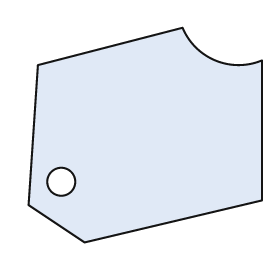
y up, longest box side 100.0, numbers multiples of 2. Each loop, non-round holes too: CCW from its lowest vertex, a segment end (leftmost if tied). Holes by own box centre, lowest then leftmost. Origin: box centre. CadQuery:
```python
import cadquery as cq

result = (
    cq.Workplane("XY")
    .moveTo(-26.0, -46.0)
    .lineTo(50.0, -28.0)
    .lineTo(50.0, 32.0)
    .threePointArc((30.0, 32.0), (16.0, 46.0))
    .lineTo(-46.0, 30.0)
    .lineTo(-50.0, -30.0)
    .close()
    .moveTo(-36.0, -20.0)
    .circle(6.0)
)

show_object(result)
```